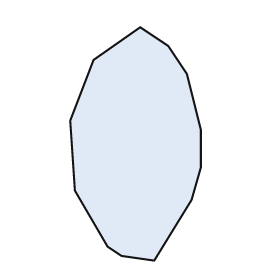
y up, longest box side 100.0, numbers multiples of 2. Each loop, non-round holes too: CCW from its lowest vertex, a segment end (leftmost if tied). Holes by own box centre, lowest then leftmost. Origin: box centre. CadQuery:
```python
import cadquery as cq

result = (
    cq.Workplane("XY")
    .moveTo(8.0, -50.0)
    .lineTo(24.0, -24.0)
    .lineTo(28.0, -10.0)
    .lineTo(28.0, 6.0)
    .lineTo(22.0, 30.0)
    .lineTo(14.0, 42.0)
    .lineTo(2.0, 50.0)
    .lineTo(-18.0, 36.0)
    .lineTo(-28.0, 10.0)
    .lineTo(-26.0, -20.0)
    .lineTo(-12.0, -44.0)
    .lineTo(-6.0, -48.0)
    .close()
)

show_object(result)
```